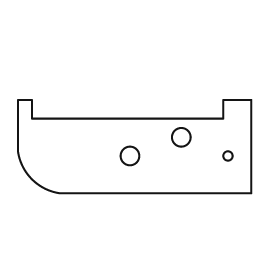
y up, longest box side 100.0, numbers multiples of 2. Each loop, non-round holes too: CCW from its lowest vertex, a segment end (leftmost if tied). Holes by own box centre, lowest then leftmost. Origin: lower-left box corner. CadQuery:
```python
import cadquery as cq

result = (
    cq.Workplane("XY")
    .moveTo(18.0, 0.0)
    .lineTo(100.0, 0.0)
    .lineTo(100.0, 40.0)
    .lineTo(88.0, 40.0)
    .lineTo(88.0, 32.0)
    .lineTo(6.0, 32.0)
    .lineTo(6.0, 40.0)
    .lineTo(0.0, 40.0)
    .lineTo(0.0, 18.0)
    .threePointArc((6.0, 6.0), (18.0, 0.0))
    .close()
    .moveTo(48.0, 16.0)
    .circle(4.0)
    .moveTo(90.0, 16.0)
    .circle(2.0)
    .moveTo(70.0, 24.0)
    .circle(4.0)
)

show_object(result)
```